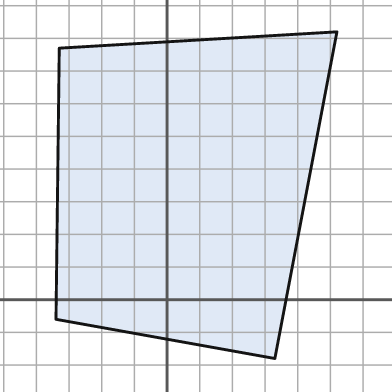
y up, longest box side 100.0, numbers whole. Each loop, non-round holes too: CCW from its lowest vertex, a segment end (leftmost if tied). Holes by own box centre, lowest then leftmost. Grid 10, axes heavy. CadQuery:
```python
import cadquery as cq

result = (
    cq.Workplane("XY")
    .moveTo(33.0, -18.0)
    .lineTo(52.0, 82.0)
    .lineTo(-33.0, 77.0)
    .lineTo(-34.0, -6.0)
    .close()
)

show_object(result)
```